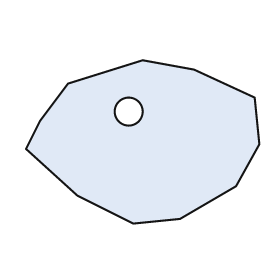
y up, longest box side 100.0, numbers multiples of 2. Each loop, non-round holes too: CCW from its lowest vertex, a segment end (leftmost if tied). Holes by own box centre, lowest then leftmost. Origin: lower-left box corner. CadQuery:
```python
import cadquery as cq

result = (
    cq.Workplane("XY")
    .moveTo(46.0, 0.0)
    .lineTo(66.0, 2.0)
    .lineTo(90.0, 16.0)
    .lineTo(100.0, 34.0)
    .lineTo(98.0, 54.0)
    .lineTo(72.0, 66.0)
    .lineTo(50.0, 70.0)
    .lineTo(18.0, 60.0)
    .lineTo(6.0, 44.0)
    .lineTo(0.0, 32.0)
    .lineTo(22.0, 12.0)
    .close()
    .moveTo(44.0, 48.0)
    .circle(6.0)
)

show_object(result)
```